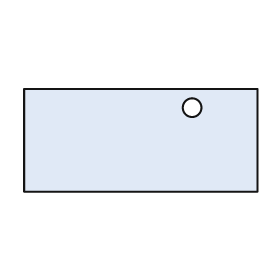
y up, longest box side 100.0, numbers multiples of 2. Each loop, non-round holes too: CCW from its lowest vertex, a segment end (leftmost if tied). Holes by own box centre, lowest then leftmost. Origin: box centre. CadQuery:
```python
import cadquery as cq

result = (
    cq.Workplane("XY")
    .moveTo(-50.0, -22.0)
    .lineTo(50.0, -22.0)
    .lineTo(50.0, 22.0)
    .lineTo(-50.0, 22.0)
    .close()
    .moveTo(22.0, 14.0)
    .circle(4.0)
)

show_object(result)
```